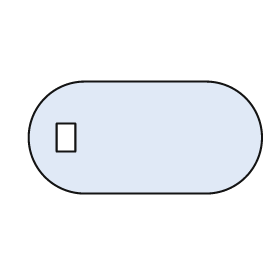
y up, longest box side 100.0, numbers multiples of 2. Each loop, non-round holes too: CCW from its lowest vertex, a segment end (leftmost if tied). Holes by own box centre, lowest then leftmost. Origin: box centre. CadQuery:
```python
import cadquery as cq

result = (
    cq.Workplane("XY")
    .moveTo(-26.0, -24.0)
    .lineTo(26.0, -24.0)
    .threePointArc((50.0, 0.0), (26.0, 24.0))
    .lineTo(-26.0, 24.0)
    .threePointArc((-50.0, 0.0), (-26.0, -24.0))
    .close()
    .moveTo(-38.0, -6.0)
    .lineTo(-30.0, -6.0)
    .lineTo(-30.0, 6.0)
    .lineTo(-38.0, 6.0)
    .close()
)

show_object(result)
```